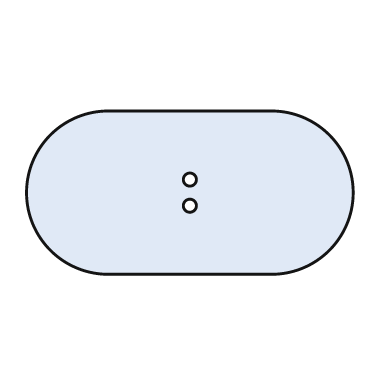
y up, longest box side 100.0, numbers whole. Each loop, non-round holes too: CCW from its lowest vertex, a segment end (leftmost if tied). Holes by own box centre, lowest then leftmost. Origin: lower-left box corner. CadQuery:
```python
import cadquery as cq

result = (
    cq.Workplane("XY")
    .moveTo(25.0, 0.0)
    .lineTo(75.0, 0.0)
    .threePointArc((100.0, 25.0), (75.0, 50.0))
    .lineTo(25.0, 50.0)
    .threePointArc((0.0, 25.0), (25.0, 0.0))
    .close()
    .moveTo(50.0, 21.0)
    .circle(2.0)
    .moveTo(50.0, 29.0)
    .circle(2.0)
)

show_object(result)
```